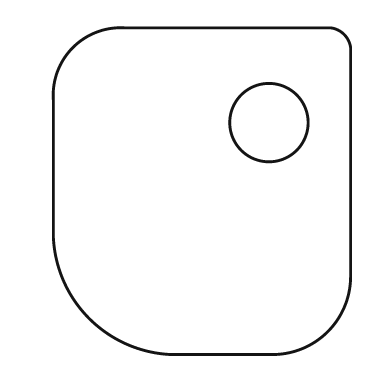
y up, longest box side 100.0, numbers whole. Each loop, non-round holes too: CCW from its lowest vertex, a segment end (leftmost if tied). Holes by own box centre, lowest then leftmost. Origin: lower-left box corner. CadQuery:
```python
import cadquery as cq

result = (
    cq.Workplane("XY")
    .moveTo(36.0, 0.0)
    .lineTo(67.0, 0.0)
    .threePointArc((84.0, 7.0), (91.0, 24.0))
    .lineTo(91.0, 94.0)
    .threePointArc((89.0, 98.0), (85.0, 100.0))
    .lineTo(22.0, 100.0)
    .threePointArc((6.0, 94.0), (0.0, 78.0))
    .lineTo(0.0, 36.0)
    .threePointArc((11.0, 11.0), (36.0, 0.0))
    .close()
    .moveTo(66.0, 71.0)
    .circle(12.0)
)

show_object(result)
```